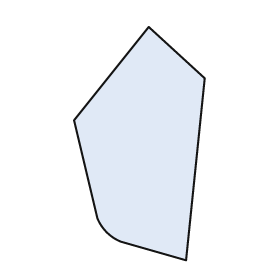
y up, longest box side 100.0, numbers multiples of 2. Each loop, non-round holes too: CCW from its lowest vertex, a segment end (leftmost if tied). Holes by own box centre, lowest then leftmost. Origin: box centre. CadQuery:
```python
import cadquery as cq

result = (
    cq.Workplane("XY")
    .moveTo(20.0, -50.0)
    .lineTo(28.0, 28.0)
    .lineTo(4.0, 50.0)
    .lineTo(-28.0, 10.0)
    .lineTo(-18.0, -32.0)
    .threePointArc((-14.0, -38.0), (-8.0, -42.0))
    .close()
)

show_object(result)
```